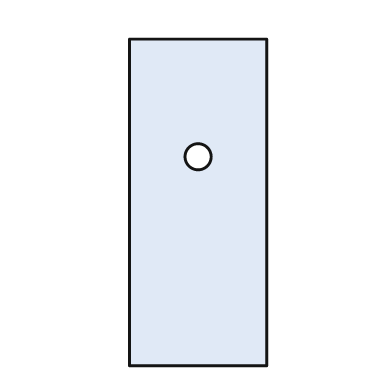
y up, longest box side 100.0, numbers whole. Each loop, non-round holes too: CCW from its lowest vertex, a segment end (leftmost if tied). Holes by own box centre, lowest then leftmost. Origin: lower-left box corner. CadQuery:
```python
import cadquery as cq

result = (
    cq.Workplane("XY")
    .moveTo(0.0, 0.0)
    .lineTo(42.0, 0.0)
    .lineTo(42.0, 100.0)
    .lineTo(0.0, 100.0)
    .close()
    .moveTo(21.0, 64.0)
    .circle(4.0)
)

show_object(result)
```